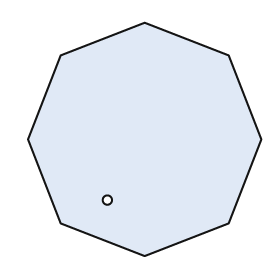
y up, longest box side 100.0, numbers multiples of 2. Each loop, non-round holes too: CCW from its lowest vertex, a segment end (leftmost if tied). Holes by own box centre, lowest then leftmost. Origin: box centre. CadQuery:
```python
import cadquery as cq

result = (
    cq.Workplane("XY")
    .moveTo(0.0, -50.0)
    .lineTo(36.0, -36.0)
    .lineTo(50.0, 0.0)
    .lineTo(36.0, 36.0)
    .lineTo(0.0, 50.0)
    .lineTo(-36.0, 36.0)
    .lineTo(-50.0, 0.0)
    .lineTo(-36.0, -36.0)
    .close()
    .moveTo(-16.0, -26.0)
    .circle(2.0)
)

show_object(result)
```